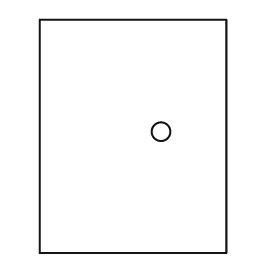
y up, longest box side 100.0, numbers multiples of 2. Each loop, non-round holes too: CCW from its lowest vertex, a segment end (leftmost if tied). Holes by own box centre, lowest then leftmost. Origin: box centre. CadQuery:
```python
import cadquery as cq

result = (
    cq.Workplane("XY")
    .moveTo(-40.0, -50.0)
    .lineTo(40.0, -50.0)
    .lineTo(40.0, 50.0)
    .lineTo(-40.0, 50.0)
    .close()
    .moveTo(12.0, 2.0)
    .circle(4.0)
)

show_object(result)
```